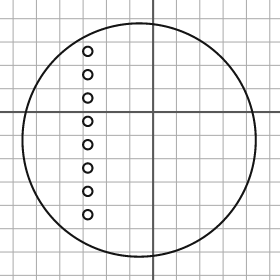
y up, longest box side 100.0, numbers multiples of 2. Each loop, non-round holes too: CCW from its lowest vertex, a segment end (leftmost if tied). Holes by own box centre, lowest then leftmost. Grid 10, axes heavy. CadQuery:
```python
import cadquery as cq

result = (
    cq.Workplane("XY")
    .moveTo(-6.0, -12.0)
    .circle(50.0)
    .moveTo(-28.0, -44.0)
    .circle(2.0)
    .moveTo(-28.0, -34.0)
    .circle(2.0)
    .moveTo(-28.0, -24.0)
    .circle(2.0)
    .moveTo(-28.0, -14.0)
    .circle(2.0)
    .moveTo(-28.0, -4.0)
    .circle(2.0)
    .moveTo(-28.0, 6.0)
    .circle(2.0)
    .moveTo(-28.0, 16.0)
    .circle(2.0)
    .moveTo(-28.0, 26.0)
    .circle(2.0)
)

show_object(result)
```